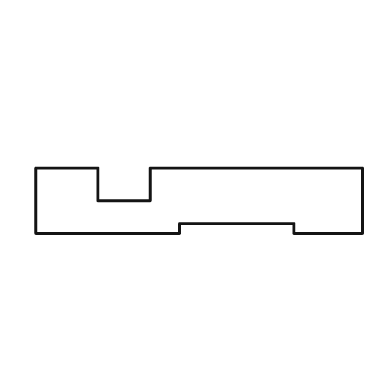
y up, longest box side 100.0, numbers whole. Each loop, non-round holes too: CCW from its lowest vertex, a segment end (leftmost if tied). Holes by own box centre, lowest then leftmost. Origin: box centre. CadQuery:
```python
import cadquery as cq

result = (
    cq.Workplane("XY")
    .moveTo(-50.0, -10.0)
    .lineTo(-6.0, -10.0)
    .lineTo(-6.0, -7.0)
    .lineTo(29.0, -7.0)
    .lineTo(29.0, -10.0)
    .lineTo(50.0, -10.0)
    .lineTo(50.0, 10.0)
    .lineTo(-15.0, 10.0)
    .lineTo(-15.0, 0.0)
    .lineTo(-31.0, 0.0)
    .lineTo(-31.0, 10.0)
    .lineTo(-50.0, 10.0)
    .close()
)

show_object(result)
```